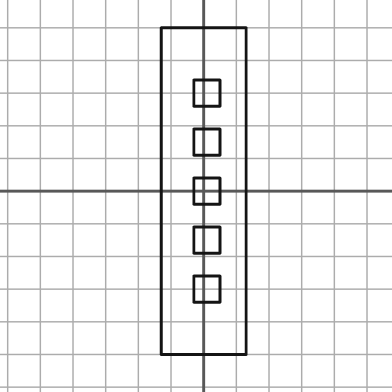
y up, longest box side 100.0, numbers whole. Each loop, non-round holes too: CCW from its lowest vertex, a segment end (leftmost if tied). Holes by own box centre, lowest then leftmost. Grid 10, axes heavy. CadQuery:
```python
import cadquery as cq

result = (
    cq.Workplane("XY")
    .moveTo(-13.0, -50.0)
    .lineTo(13.0, -50.0)
    .lineTo(13.0, 50.0)
    .lineTo(-13.0, 50.0)
    .close()
    .moveTo(-3.0, -34.0)
    .lineTo(5.0, -34.0)
    .lineTo(5.0, -26.0)
    .lineTo(-3.0, -26.0)
    .close()
    .moveTo(-3.0, -19.0)
    .lineTo(5.0, -19.0)
    .lineTo(5.0, -11.0)
    .lineTo(-3.0, -11.0)
    .close()
    .moveTo(-3.0, -4.0)
    .lineTo(5.0, -4.0)
    .lineTo(5.0, 4.0)
    .lineTo(-3.0, 4.0)
    .close()
    .moveTo(-3.0, 11.0)
    .lineTo(5.0, 11.0)
    .lineTo(5.0, 19.0)
    .lineTo(-3.0, 19.0)
    .close()
    .moveTo(-3.0, 26.0)
    .lineTo(5.0, 26.0)
    .lineTo(5.0, 34.0)
    .lineTo(-3.0, 34.0)
    .close()
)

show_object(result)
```